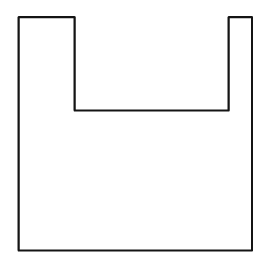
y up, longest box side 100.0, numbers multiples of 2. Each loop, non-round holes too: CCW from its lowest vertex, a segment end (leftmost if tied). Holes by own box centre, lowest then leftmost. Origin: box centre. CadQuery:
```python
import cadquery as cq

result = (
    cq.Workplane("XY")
    .moveTo(-50.0, -50.0)
    .lineTo(50.0, -50.0)
    .lineTo(50.0, 50.0)
    .lineTo(40.0, 50.0)
    .lineTo(40.0, 10.0)
    .lineTo(-26.0, 10.0)
    .lineTo(-26.0, 50.0)
    .lineTo(-50.0, 50.0)
    .close()
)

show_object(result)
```